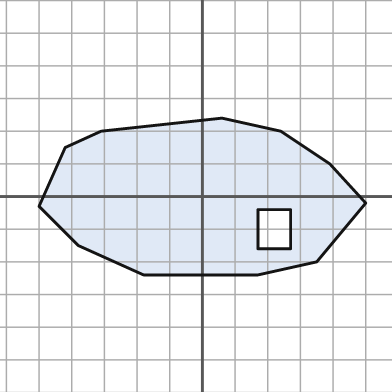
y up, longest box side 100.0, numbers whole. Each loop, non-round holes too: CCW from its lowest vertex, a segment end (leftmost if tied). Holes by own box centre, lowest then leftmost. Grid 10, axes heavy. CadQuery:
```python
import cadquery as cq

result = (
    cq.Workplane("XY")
    .moveTo(-18.0, -24.0)
    .lineTo(17.0, -24.0)
    .lineTo(35.0, -20.0)
    .lineTo(50.0, -2.0)
    .lineTo(39.0, 10.0)
    .lineTo(24.0, 20.0)
    .lineTo(6.0, 24.0)
    .lineTo(-31.0, 20.0)
    .lineTo(-42.0, 15.0)
    .lineTo(-50.0, -3.0)
    .lineTo(-38.0, -15.0)
    .close()
    .moveTo(17.0, -16.0)
    .lineTo(27.0, -16.0)
    .lineTo(27.0, -4.0)
    .lineTo(17.0, -4.0)
    .close()
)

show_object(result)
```